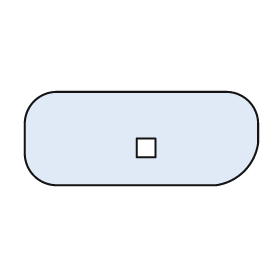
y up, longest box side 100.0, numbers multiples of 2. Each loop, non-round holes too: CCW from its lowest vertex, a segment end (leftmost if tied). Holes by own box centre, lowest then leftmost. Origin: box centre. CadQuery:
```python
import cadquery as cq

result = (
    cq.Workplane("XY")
    .moveTo(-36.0, -20.0)
    .lineTo(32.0, -20.0)
    .threePointArc((44.0, -14.0), (50.0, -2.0))
    .lineTo(50.0, 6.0)
    .threePointArc((46.0, 16.0), (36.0, 20.0))
    .lineTo(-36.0, 20.0)
    .threePointArc((-46.0, 16.0), (-50.0, 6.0))
    .lineTo(-50.0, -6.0)
    .threePointArc((-46.0, -16.0), (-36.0, -20.0))
    .close()
    .moveTo(-2.0, -8.0)
    .lineTo(6.0, -8.0)
    .lineTo(6.0, 0.0)
    .lineTo(-2.0, 0.0)
    .close()
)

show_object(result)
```